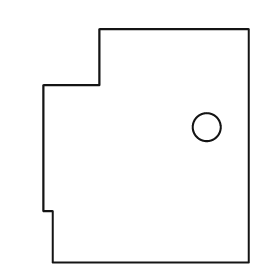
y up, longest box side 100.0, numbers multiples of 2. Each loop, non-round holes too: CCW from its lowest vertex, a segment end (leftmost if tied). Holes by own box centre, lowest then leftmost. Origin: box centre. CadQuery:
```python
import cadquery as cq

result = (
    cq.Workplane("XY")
    .moveTo(-40.0, -50.0)
    .lineTo(44.0, -50.0)
    .lineTo(44.0, 50.0)
    .lineTo(-20.0, 50.0)
    .lineTo(-20.0, 26.0)
    .lineTo(-44.0, 26.0)
    .lineTo(-44.0, -28.0)
    .lineTo(-40.0, -28.0)
    .close()
    .moveTo(26.0, 8.0)
    .circle(6.0)
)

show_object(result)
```